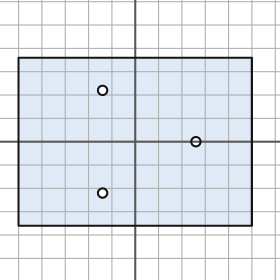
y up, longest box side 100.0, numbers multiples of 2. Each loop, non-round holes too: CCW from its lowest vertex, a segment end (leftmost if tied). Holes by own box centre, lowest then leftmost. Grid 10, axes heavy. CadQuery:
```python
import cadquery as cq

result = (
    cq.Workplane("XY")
    .moveTo(-50.0, -36.0)
    .lineTo(50.0, -36.0)
    .lineTo(50.0, 36.0)
    .lineTo(-50.0, 36.0)
    .close()
    .moveTo(-14.0, -22.0)
    .circle(2.0)
    .moveTo(26.0, 0.0)
    .circle(2.0)
    .moveTo(-14.0, 22.0)
    .circle(2.0)
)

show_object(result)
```